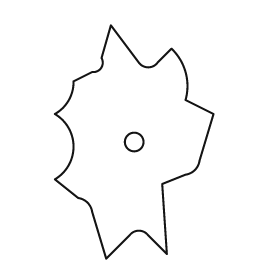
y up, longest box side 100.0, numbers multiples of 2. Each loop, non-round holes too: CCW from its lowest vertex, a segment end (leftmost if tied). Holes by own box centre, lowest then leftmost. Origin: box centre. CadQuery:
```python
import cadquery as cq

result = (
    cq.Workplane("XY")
    .moveTo(-12.0, -50.0)
    .lineTo(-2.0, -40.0)
    .threePointArc((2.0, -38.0), (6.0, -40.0))
    .lineTo(14.0, -48.0)
    .lineTo(12.0, -18.0)
    .lineTo(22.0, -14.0)
    .threePointArc((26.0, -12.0), (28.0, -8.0))
    .lineTo(34.0, 12.0)
    .lineTo(22.0, 18.0)
    .threePointArc((22.0, 30.0), (16.0, 40.0))
    .lineTo(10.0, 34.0)
    .threePointArc((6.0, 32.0), (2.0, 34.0))
    .lineTo(-10.0, 50.0)
    .lineTo(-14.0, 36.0)
    .threePointArc((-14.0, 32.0), (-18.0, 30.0))
    .lineTo(-26.0, 26.0)
    .threePointArc((-28.0, 18.0), (-34.0, 12.0))
    .threePointArc((-26.0, -2.0), (-34.0, -16.0))
    .lineTo(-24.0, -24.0)
    .threePointArc((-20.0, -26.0), (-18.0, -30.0))
    .close()
    .moveTo(0.0, 0.0)
    .circle(4.0)
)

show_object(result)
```